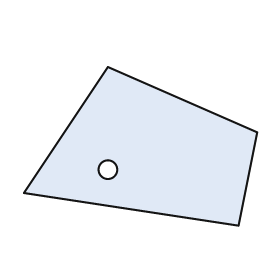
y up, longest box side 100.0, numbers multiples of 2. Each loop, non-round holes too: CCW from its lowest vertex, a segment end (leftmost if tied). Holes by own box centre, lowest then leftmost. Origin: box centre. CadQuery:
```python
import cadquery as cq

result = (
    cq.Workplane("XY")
    .moveTo(42.0, -34.0)
    .lineTo(50.0, 6.0)
    .lineTo(-14.0, 34.0)
    .lineTo(-50.0, -20.0)
    .close()
    .moveTo(-14.0, -10.0)
    .circle(4.0)
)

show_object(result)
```